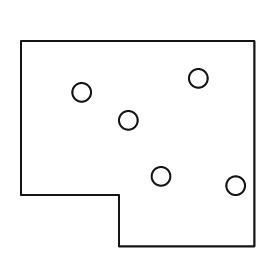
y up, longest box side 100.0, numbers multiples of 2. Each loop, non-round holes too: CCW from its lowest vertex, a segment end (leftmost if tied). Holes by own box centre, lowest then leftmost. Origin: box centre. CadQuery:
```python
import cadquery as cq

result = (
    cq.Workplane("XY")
    .moveTo(-8.0, -44.0)
    .lineTo(50.0, -44.0)
    .lineTo(50.0, 44.0)
    .lineTo(-50.0, 44.0)
    .lineTo(-50.0, -22.0)
    .lineTo(-8.0, -22.0)
    .close()
    .moveTo(42.0, -18.0)
    .circle(4.0)
    .moveTo(10.0, -14.0)
    .circle(4.0)
    .moveTo(-4.0, 10.0)
    .circle(4.0)
    .moveTo(-24.0, 22.0)
    .circle(4.0)
    .moveTo(26.0, 28.0)
    .circle(4.0)
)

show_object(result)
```